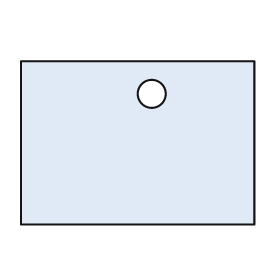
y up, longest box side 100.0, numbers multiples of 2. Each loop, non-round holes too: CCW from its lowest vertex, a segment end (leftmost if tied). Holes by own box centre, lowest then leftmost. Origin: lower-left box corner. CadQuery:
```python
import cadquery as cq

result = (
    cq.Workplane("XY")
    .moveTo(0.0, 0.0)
    .lineTo(100.0, 0.0)
    .lineTo(100.0, 70.0)
    .lineTo(0.0, 70.0)
    .close()
    .moveTo(56.0, 56.0)
    .circle(6.0)
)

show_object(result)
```